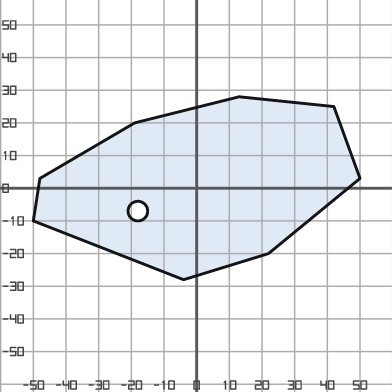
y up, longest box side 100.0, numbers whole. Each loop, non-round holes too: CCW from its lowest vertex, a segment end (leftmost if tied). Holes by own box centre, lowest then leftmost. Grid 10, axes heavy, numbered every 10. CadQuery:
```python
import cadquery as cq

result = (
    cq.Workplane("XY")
    .moveTo(-4.0, -28.0)
    .lineTo(22.0, -20.0)
    .lineTo(50.0, 3.0)
    .lineTo(42.0, 25.0)
    .lineTo(13.0, 28.0)
    .lineTo(-19.0, 20.0)
    .lineTo(-48.0, 3.0)
    .lineTo(-50.0, -10.0)
    .close()
    .moveTo(-18.0, -7.0)
    .circle(3.0)
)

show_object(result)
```